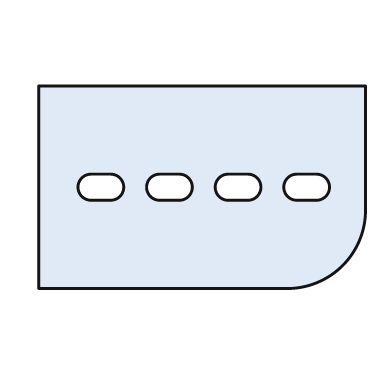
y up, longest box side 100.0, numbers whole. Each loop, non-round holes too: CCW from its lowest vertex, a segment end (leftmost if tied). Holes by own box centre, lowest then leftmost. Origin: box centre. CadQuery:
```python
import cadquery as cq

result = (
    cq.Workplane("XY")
    .moveTo(-50.0, -31.0)
    .lineTo(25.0, -31.0)
    .threePointArc((43.0, -24.0), (50.0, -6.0))
    .lineTo(50.0, 31.0)
    .lineTo(-50.0, 31.0)
    .close()
    .moveTo(-34.0, -4.0)
    .lineTo(-28.0, -4.0)
    .threePointArc((-24.0, 0.0), (-28.0, 4.0))
    .lineTo(-34.0, 4.0)
    .threePointArc((-38.0, 0.0), (-34.0, -4.0))
    .close()
    .moveTo(-13.0, -4.0)
    .lineTo(-7.0, -4.0)
    .threePointArc((-3.0, 0.0), (-7.0, 4.0))
    .lineTo(-13.0, 4.0)
    .threePointArc((-17.0, 0.0), (-13.0, -4.0))
    .close()
    .moveTo(8.0, -4.0)
    .lineTo(14.0, -4.0)
    .threePointArc((18.0, 0.0), (14.0, 4.0))
    .lineTo(8.0, 4.0)
    .threePointArc((4.0, 0.0), (8.0, -4.0))
    .close()
    .moveTo(29.0, -4.0)
    .lineTo(35.0, -4.0)
    .threePointArc((39.0, 0.0), (35.0, 4.0))
    .lineTo(29.0, 4.0)
    .threePointArc((25.0, 0.0), (29.0, -4.0))
    .close()
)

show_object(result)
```